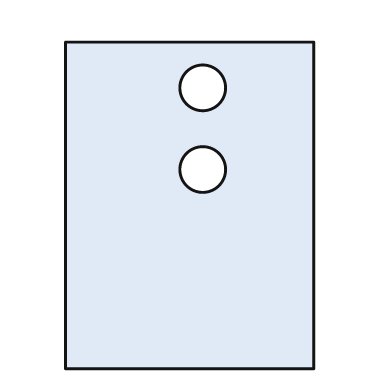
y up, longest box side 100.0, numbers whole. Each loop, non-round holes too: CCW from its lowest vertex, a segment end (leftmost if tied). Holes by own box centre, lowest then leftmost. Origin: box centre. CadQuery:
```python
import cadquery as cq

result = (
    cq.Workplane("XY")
    .moveTo(-38.0, -50.0)
    .lineTo(38.0, -50.0)
    .lineTo(38.0, 50.0)
    .lineTo(-38.0, 50.0)
    .close()
    .moveTo(4.0, 11.0)
    .circle(7.0)
    .moveTo(4.0, 36.0)
    .circle(7.0)
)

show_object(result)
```